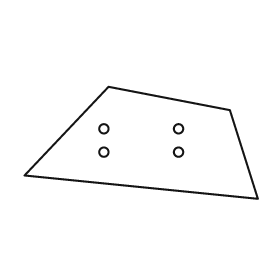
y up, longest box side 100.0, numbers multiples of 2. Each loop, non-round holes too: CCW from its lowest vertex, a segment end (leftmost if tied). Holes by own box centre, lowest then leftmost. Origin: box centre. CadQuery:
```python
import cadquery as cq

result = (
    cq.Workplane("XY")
    .moveTo(50.0, -24.0)
    .lineTo(38.0, 14.0)
    .lineTo(-14.0, 24.0)
    .lineTo(-50.0, -14.0)
    .close()
    .moveTo(-16.0, -4.0)
    .circle(2.0)
    .moveTo(16.0, -4.0)
    .circle(2.0)
    .moveTo(-16.0, 6.0)
    .circle(2.0)
    .moveTo(16.0, 6.0)
    .circle(2.0)
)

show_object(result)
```